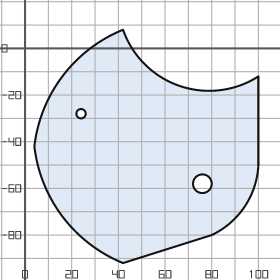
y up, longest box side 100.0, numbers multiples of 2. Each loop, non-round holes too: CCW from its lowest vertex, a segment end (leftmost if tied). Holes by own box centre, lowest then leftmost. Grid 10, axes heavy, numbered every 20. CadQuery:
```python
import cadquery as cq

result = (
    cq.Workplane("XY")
    .moveTo(42.0, -92.0)
    .lineTo(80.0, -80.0)
    .threePointArc((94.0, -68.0), (100.0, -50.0))
    .lineTo(100.0, -12.0)
    .threePointArc((66.0, -16.0), (42.0, 8.0))
    .threePointArc((16.0, -12.0), (4.0, -42.0))
    .threePointArc((16.0, -72.0), (42.0, -92.0))
    .close()
    .moveTo(76.0, -58.0)
    .circle(4.0)
    .moveTo(24.0, -28.0)
    .circle(2.0)
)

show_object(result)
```